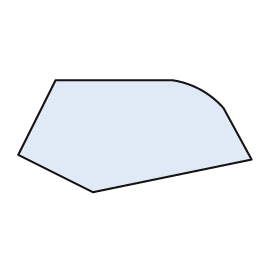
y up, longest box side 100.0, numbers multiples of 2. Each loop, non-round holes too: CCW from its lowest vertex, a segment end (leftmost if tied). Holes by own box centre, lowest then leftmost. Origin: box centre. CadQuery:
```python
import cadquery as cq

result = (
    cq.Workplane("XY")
    .moveTo(-18.0, -24.0)
    .lineTo(50.0, -10.0)
    .lineTo(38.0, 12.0)
    .threePointArc((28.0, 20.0), (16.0, 24.0))
    .lineTo(-34.0, 24.0)
    .lineTo(-50.0, -8.0)
    .close()
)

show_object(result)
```